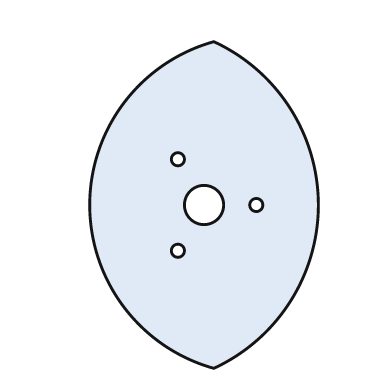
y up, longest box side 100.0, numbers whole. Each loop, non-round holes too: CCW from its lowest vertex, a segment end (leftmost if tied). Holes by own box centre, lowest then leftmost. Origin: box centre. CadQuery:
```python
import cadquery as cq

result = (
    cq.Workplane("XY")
    .moveTo(3.0, -50.0)
    .threePointArc((35.0, 0.0), (3.0, 50.0))
    .threePointArc((-35.0, 0.0), (3.0, -50.0))
    .close()
    .moveTo(-8.0, -14.0)
    .circle(2.0)
    .moveTo(0.0, 0.0)
    .circle(6.0)
    .moveTo(16.0, 0.0)
    .circle(2.0)
    .moveTo(-8.0, 14.0)
    .circle(2.0)
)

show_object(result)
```